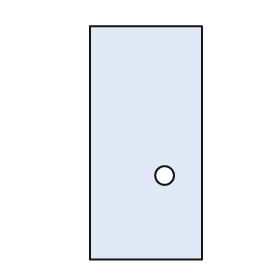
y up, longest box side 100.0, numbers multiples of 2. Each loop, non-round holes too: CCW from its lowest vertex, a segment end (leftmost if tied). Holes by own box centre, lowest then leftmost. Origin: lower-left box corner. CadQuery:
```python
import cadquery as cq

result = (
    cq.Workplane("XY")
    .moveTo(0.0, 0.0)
    .lineTo(48.0, 0.0)
    .lineTo(48.0, 100.0)
    .lineTo(0.0, 100.0)
    .close()
    .moveTo(32.0, 36.0)
    .circle(4.0)
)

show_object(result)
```